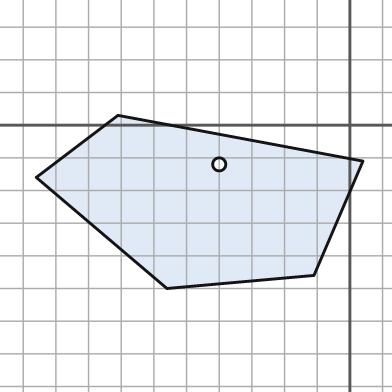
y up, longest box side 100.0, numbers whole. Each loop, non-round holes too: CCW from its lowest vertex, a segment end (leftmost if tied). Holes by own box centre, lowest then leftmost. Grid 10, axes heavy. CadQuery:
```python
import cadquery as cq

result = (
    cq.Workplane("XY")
    .moveTo(-56.0, -50.0)
    .lineTo(-11.0, -46.0)
    .lineTo(4.0, -11.0)
    .lineTo(-71.0, 3.0)
    .lineTo(-96.0, -16.0)
    .close()
    .moveTo(-40.0, -12.0)
    .circle(2.0)
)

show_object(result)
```